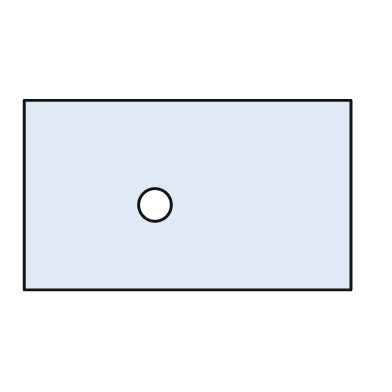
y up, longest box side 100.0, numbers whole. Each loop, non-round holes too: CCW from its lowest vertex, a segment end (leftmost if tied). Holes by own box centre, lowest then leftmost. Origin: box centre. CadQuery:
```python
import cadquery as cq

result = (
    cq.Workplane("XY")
    .moveTo(-50.0, -29.0)
    .lineTo(50.0, -29.0)
    .lineTo(50.0, 29.0)
    .lineTo(-50.0, 29.0)
    .close()
    .moveTo(-10.0, -3.0)
    .circle(5.0)
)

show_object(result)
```